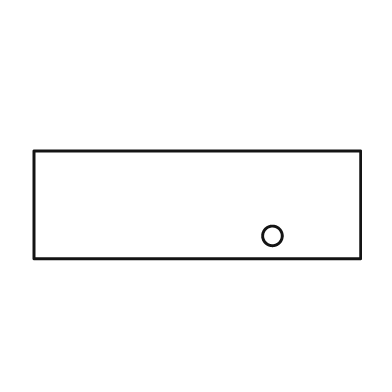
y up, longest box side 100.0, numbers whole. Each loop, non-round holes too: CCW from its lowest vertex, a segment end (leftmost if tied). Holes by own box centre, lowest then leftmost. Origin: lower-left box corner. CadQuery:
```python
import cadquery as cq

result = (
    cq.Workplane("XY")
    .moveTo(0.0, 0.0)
    .lineTo(100.0, 0.0)
    .lineTo(100.0, 33.0)
    .lineTo(0.0, 33.0)
    .close()
    .moveTo(73.0, 7.0)
    .circle(3.0)
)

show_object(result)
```